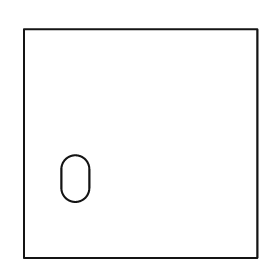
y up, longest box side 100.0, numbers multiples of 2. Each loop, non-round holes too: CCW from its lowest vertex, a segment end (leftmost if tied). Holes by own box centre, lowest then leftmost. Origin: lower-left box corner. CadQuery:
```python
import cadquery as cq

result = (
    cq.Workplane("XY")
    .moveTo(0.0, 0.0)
    .lineTo(100.0, 0.0)
    .lineTo(100.0, 98.0)
    .lineTo(0.0, 98.0)
    .close()
    .moveTo(16.0, 30.0)
    .threePointArc((22.0, 24.0), (28.0, 30.0))
    .lineTo(28.0, 38.0)
    .threePointArc((22.0, 44.0), (16.0, 38.0))
    .close()
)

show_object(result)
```